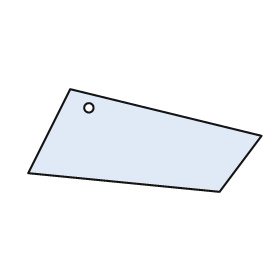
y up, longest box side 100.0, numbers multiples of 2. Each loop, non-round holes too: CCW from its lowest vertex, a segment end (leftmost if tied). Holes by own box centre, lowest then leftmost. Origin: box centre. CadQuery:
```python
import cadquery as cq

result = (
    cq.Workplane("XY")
    .moveTo(32.0, -22.0)
    .lineTo(50.0, 2.0)
    .lineTo(-32.0, 22.0)
    .lineTo(-50.0, -14.0)
    .close()
    .moveTo(-24.0, 14.0)
    .circle(2.0)
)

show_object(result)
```